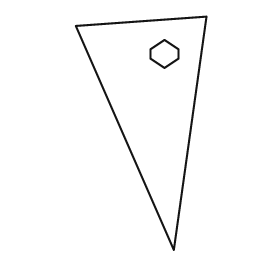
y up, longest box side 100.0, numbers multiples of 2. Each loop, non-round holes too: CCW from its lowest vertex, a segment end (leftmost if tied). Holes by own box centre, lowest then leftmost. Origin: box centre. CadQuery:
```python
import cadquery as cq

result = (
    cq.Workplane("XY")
    .moveTo(14.0, -50.0)
    .lineTo(28.0, 50.0)
    .lineTo(-28.0, 46.0)
    .close()
    .moveTo(10.0, 28.0)
    .lineTo(16.0, 32.0)
    .lineTo(16.0, 36.0)
    .lineTo(10.0, 40.0)
    .lineTo(4.0, 36.0)
    .lineTo(4.0, 32.0)
    .close()
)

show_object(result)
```